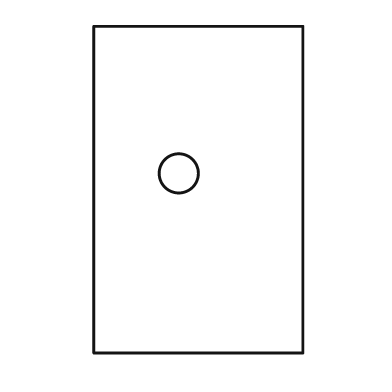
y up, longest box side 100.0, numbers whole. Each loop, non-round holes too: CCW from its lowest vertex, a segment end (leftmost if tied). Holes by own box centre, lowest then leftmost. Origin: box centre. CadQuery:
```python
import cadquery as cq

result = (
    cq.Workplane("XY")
    .moveTo(-32.0, -50.0)
    .lineTo(32.0, -50.0)
    .lineTo(32.0, 50.0)
    .lineTo(-32.0, 50.0)
    .close()
    .moveTo(-6.0, 5.0)
    .circle(6.0)
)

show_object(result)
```